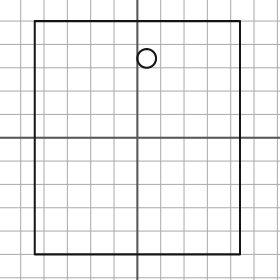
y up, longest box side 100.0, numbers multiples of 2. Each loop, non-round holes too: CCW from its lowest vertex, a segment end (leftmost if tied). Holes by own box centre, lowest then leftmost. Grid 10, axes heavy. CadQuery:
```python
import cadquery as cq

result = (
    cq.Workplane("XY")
    .moveTo(-44.0, -50.0)
    .lineTo(44.0, -50.0)
    .lineTo(44.0, 50.0)
    .lineTo(-44.0, 50.0)
    .close()
    .moveTo(4.0, 34.0)
    .circle(4.0)
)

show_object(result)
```